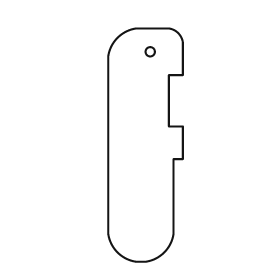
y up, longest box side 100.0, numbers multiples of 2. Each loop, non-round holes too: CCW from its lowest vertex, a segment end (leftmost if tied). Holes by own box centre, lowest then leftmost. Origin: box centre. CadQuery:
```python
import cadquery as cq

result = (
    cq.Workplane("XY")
    .moveTo(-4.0, -50.0)
    .lineTo(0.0, -50.0)
    .threePointArc((8.0, -46.0), (12.0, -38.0))
    .lineTo(12.0, -6.0)
    .lineTo(16.0, -6.0)
    .lineTo(16.0, 8.0)
    .lineTo(10.0, 8.0)
    .lineTo(10.0, 30.0)
    .lineTo(16.0, 30.0)
    .lineTo(16.0, 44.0)
    .threePointArc((14.0, 48.0), (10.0, 50.0))
    .lineTo(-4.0, 50.0)
    .threePointArc((-12.0, 46.0), (-16.0, 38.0))
    .lineTo(-16.0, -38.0)
    .threePointArc((-12.0, -46.0), (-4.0, -50.0))
    .close()
    .moveTo(2.0, 40.0)
    .circle(2.0)
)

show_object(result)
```